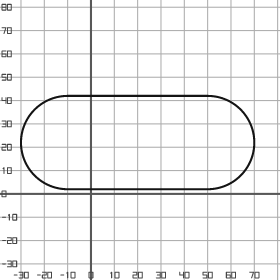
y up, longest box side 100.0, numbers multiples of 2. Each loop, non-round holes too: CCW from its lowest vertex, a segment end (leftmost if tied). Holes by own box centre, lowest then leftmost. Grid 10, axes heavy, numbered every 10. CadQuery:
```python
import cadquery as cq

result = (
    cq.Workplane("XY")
    .moveTo(-10.0, 2.0)
    .lineTo(50.0, 2.0)
    .threePointArc((70.0, 22.0), (50.0, 42.0))
    .lineTo(-10.0, 42.0)
    .threePointArc((-30.0, 22.0), (-10.0, 2.0))
    .close()
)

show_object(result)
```